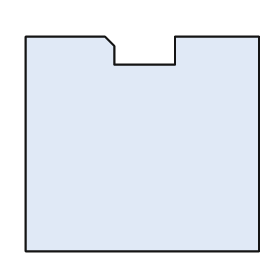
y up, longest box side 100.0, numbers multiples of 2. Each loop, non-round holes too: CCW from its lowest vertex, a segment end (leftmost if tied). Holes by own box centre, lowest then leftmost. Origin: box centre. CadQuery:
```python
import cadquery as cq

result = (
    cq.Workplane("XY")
    .moveTo(-50.0, -46.0)
    .lineTo(50.0, -46.0)
    .lineTo(50.0, 46.0)
    .lineTo(14.0, 46.0)
    .lineTo(14.0, 34.0)
    .lineTo(-12.0, 34.0)
    .lineTo(-12.0, 42.0)
    .lineTo(-16.0, 46.0)
    .lineTo(-50.0, 46.0)
    .close()
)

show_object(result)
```